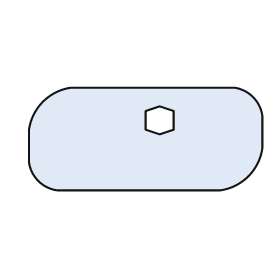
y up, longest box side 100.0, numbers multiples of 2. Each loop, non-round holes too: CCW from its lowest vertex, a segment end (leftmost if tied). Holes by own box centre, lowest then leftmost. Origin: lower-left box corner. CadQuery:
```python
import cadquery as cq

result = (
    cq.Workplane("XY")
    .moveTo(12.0, 0.0)
    .lineTo(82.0, 0.0)
    .threePointArc((94.0, 6.0), (100.0, 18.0))
    .lineTo(100.0, 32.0)
    .threePointArc((96.0, 40.0), (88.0, 44.0))
    .lineTo(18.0, 44.0)
    .threePointArc((6.0, 38.0), (0.0, 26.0))
    .lineTo(0.0, 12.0)
    .threePointArc((4.0, 4.0), (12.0, 0.0))
    .close()
    .moveTo(56.0, 24.0)
    .lineTo(62.0, 26.0)
    .lineTo(62.0, 34.0)
    .lineTo(56.0, 36.0)
    .lineTo(50.0, 34.0)
    .lineTo(50.0, 26.0)
    .close()
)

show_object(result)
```